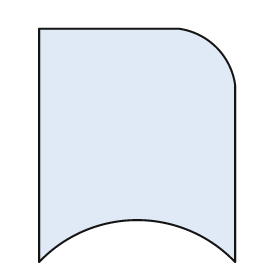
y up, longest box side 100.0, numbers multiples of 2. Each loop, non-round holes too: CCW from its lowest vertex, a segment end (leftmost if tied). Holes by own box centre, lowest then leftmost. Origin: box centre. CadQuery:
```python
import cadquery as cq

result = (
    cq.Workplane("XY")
    .moveTo(-42.0, -50.0)
    .threePointArc((0.0, -32.0), (42.0, -50.0))
    .lineTo(42.0, 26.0)
    .threePointArc((34.0, 42.0), (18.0, 50.0))
    .lineTo(-42.0, 50.0)
    .close()
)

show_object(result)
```